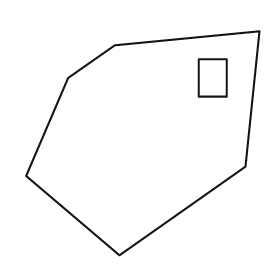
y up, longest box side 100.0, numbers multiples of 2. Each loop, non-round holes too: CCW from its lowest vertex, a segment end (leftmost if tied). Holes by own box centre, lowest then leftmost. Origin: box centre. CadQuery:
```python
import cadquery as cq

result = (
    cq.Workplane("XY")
    .moveTo(-10.0, -48.0)
    .lineTo(44.0, -10.0)
    .lineTo(50.0, 48.0)
    .lineTo(-12.0, 42.0)
    .lineTo(-32.0, 28.0)
    .lineTo(-50.0, -14.0)
    .close()
    .moveTo(24.0, 20.0)
    .lineTo(36.0, 20.0)
    .lineTo(36.0, 36.0)
    .lineTo(24.0, 36.0)
    .close()
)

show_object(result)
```